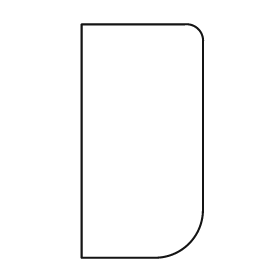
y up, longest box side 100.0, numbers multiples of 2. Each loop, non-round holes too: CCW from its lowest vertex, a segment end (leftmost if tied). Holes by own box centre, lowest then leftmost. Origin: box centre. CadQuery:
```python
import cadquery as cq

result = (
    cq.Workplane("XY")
    .moveTo(-26.0, -50.0)
    .lineTo(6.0, -50.0)
    .threePointArc((20.0, -44.0), (26.0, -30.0))
    .lineTo(26.0, 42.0)
    .threePointArc((24.0, 48.0), (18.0, 50.0))
    .lineTo(-26.0, 50.0)
    .close()
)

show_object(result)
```